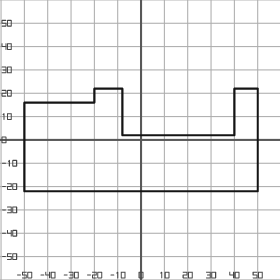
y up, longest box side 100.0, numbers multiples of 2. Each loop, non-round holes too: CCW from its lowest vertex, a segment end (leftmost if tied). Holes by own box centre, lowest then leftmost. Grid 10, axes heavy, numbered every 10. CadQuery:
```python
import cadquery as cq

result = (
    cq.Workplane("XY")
    .moveTo(-50.0, -22.0)
    .lineTo(50.0, -22.0)
    .lineTo(50.0, 22.0)
    .lineTo(40.0, 22.0)
    .lineTo(40.0, 2.0)
    .lineTo(-8.0, 2.0)
    .lineTo(-8.0, 22.0)
    .lineTo(-20.0, 22.0)
    .lineTo(-20.0, 16.0)
    .lineTo(-50.0, 16.0)
    .close()
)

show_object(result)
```